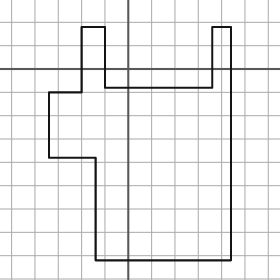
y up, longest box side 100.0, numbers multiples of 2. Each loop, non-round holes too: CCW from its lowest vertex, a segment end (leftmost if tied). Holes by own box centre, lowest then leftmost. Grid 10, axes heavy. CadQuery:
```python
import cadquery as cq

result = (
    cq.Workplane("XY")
    .moveTo(-14.0, -82.0)
    .lineTo(44.0, -82.0)
    .lineTo(44.0, 18.0)
    .lineTo(36.0, 18.0)
    .lineTo(36.0, -8.0)
    .lineTo(-10.0, -8.0)
    .lineTo(-10.0, 18.0)
    .lineTo(-20.0, 18.0)
    .lineTo(-20.0, -10.0)
    .lineTo(-34.0, -10.0)
    .lineTo(-34.0, -38.0)
    .lineTo(-14.0, -38.0)
    .close()
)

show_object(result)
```